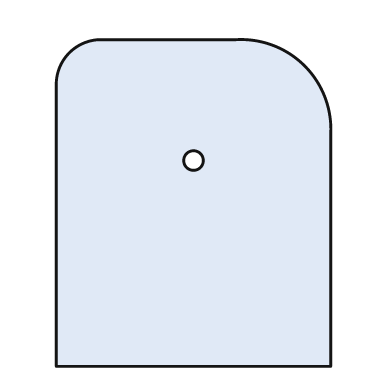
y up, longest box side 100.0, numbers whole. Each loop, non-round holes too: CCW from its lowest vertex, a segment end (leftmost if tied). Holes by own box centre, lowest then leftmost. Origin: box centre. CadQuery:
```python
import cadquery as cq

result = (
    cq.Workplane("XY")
    .moveTo(-42.0, -50.0)
    .lineTo(42.0, -50.0)
    .lineTo(42.0, 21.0)
    .threePointArc((34.0, 42.0), (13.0, 50.0))
    .lineTo(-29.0, 50.0)
    .threePointArc((-38.0, 46.0), (-42.0, 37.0))
    .close()
    .moveTo(0.0, 13.0)
    .circle(3.0)
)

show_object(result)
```